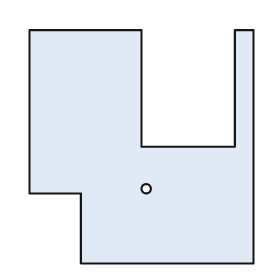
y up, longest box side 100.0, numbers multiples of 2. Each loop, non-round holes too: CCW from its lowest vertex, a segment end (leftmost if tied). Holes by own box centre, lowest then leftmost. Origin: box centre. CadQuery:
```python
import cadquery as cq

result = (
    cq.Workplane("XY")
    .moveTo(-26.0, -50.0)
    .lineTo(48.0, -50.0)
    .lineTo(48.0, 50.0)
    .lineTo(40.0, 50.0)
    .lineTo(40.0, 0.0)
    .lineTo(0.0, 0.0)
    .lineTo(0.0, 50.0)
    .lineTo(-48.0, 50.0)
    .lineTo(-48.0, -20.0)
    .lineTo(-26.0, -20.0)
    .close()
    .moveTo(2.0, -18.0)
    .circle(2.0)
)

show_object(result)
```